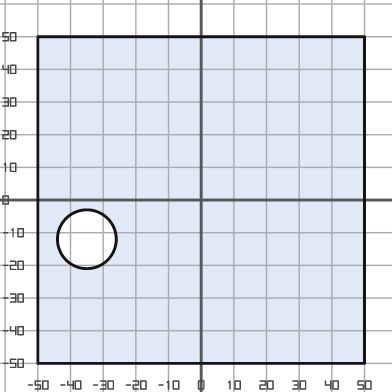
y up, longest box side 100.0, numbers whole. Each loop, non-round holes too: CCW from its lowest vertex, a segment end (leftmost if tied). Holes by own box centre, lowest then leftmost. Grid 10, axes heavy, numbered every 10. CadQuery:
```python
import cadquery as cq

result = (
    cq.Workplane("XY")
    .moveTo(-50.0, -50.0)
    .lineTo(50.0, -50.0)
    .lineTo(50.0, 50.0)
    .lineTo(-50.0, 50.0)
    .close()
    .moveTo(-35.0, -12.0)
    .circle(9.0)
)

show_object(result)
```